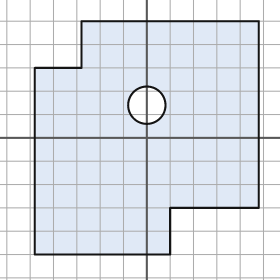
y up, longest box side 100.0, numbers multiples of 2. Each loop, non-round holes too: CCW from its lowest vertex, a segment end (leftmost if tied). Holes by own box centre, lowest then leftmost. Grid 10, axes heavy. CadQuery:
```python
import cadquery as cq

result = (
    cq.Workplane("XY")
    .moveTo(-48.0, -50.0)
    .lineTo(10.0, -50.0)
    .lineTo(10.0, -30.0)
    .lineTo(48.0, -30.0)
    .lineTo(48.0, 50.0)
    .lineTo(-28.0, 50.0)
    .lineTo(-28.0, 30.0)
    .lineTo(-48.0, 30.0)
    .close()
    .moveTo(0.0, 14.0)
    .circle(8.0)
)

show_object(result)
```